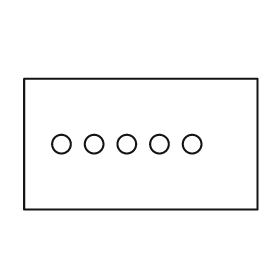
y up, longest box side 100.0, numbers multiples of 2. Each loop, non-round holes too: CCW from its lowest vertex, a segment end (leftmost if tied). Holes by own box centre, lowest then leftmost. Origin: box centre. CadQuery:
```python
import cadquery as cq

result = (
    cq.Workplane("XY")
    .moveTo(-50.0, -28.0)
    .lineTo(50.0, -28.0)
    .lineTo(50.0, 28.0)
    .lineTo(-50.0, 28.0)
    .close()
    .moveTo(-34.0, 0.0)
    .circle(4.0)
    .moveTo(-20.0, 0.0)
    .circle(4.0)
    .moveTo(-6.0, 0.0)
    .circle(4.0)
    .moveTo(8.0, 0.0)
    .circle(4.0)
    .moveTo(22.0, 0.0)
    .circle(4.0)
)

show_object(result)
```